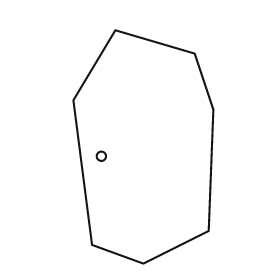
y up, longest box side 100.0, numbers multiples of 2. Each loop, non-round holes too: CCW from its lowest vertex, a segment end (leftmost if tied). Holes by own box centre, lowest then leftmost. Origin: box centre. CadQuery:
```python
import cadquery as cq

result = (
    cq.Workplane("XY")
    .moveTo(0.0, -50.0)
    .lineTo(28.0, -36.0)
    .lineTo(30.0, 16.0)
    .lineTo(22.0, 40.0)
    .lineTo(-12.0, 50.0)
    .lineTo(-30.0, 20.0)
    .lineTo(-22.0, -42.0)
    .close()
    .moveTo(-18.0, -4.0)
    .circle(2.0)
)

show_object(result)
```